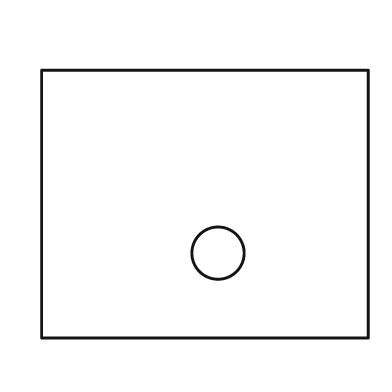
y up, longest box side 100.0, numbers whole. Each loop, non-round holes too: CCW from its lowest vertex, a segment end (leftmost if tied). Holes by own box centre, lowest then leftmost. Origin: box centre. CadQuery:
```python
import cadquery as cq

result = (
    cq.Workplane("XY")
    .moveTo(-50.0, -41.0)
    .lineTo(50.0, -41.0)
    .lineTo(50.0, 41.0)
    .lineTo(-50.0, 41.0)
    .close()
    .moveTo(4.0, -15.0)
    .circle(8.0)
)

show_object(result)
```